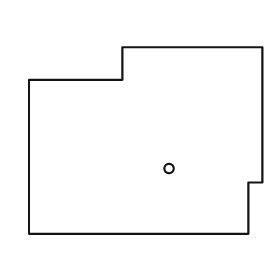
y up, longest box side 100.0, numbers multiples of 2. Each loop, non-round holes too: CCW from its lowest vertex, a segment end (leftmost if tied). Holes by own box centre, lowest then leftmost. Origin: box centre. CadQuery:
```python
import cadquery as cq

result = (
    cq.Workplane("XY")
    .moveTo(-50.0, -40.0)
    .lineTo(44.0, -40.0)
    .lineTo(44.0, -18.0)
    .lineTo(50.0, -18.0)
    .lineTo(50.0, 40.0)
    .lineTo(-10.0, 40.0)
    .lineTo(-10.0, 26.0)
    .lineTo(-50.0, 26.0)
    .close()
    .moveTo(10.0, -12.0)
    .circle(2.0)
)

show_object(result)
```